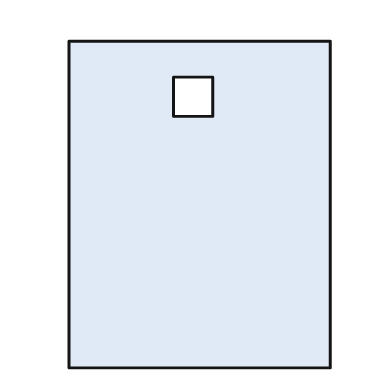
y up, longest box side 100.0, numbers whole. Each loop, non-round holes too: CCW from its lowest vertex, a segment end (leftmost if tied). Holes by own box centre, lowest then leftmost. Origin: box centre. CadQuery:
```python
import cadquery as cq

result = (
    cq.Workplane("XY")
    .moveTo(-40.0, -50.0)
    .lineTo(40.0, -50.0)
    .lineTo(40.0, 50.0)
    .lineTo(-40.0, 50.0)
    .close()
    .moveTo(-8.0, 27.0)
    .lineTo(4.0, 27.0)
    .lineTo(4.0, 39.0)
    .lineTo(-8.0, 39.0)
    .close()
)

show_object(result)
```